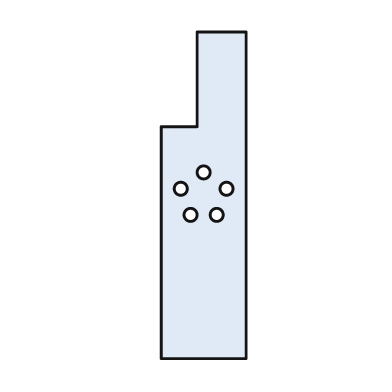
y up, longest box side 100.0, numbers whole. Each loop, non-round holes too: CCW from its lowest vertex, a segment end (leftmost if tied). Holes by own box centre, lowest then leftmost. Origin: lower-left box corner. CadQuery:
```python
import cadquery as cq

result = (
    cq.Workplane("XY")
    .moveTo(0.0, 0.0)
    .lineTo(26.0, 0.0)
    .lineTo(26.0, 100.0)
    .lineTo(11.0, 100.0)
    .lineTo(11.0, 71.0)
    .lineTo(0.0, 71.0)
    .close()
    .moveTo(9.0, 44.0)
    .circle(2.0)
    .moveTo(17.0, 44.0)
    .circle(2.0)
    .moveTo(6.0, 52.0)
    .circle(2.0)
    .moveTo(20.0, 52.0)
    .circle(2.0)
    .moveTo(13.0, 57.0)
    .circle(2.0)
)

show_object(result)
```